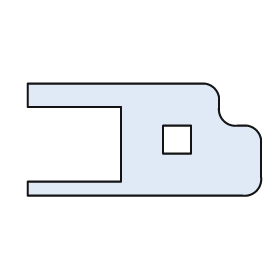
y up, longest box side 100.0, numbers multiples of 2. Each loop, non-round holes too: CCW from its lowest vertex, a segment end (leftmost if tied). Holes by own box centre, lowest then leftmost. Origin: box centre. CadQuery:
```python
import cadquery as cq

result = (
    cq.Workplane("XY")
    .moveTo(-50.0, -24.0)
    .lineTo(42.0, -24.0)
    .threePointArc((48.0, -22.0), (50.0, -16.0))
    .lineTo(50.0, 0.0)
    .threePointArc((48.0, 4.0), (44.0, 6.0))
    .lineTo(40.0, 6.0)
    .threePointArc((34.0, 8.0), (32.0, 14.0))
    .lineTo(32.0, 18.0)
    .threePointArc((30.0, 22.0), (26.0, 24.0))
    .lineTo(-50.0, 24.0)
    .lineTo(-50.0, 14.0)
    .lineTo(-10.0, 14.0)
    .lineTo(-10.0, -18.0)
    .lineTo(-50.0, -18.0)
    .close()
    .moveTo(8.0, -6.0)
    .lineTo(20.0, -6.0)
    .lineTo(20.0, 6.0)
    .lineTo(8.0, 6.0)
    .close()
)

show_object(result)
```